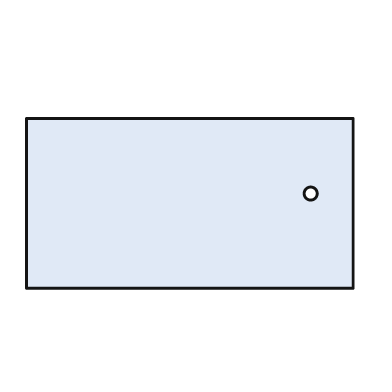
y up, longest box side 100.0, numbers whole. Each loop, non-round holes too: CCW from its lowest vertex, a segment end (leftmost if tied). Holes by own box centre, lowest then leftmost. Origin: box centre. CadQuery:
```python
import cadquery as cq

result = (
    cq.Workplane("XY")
    .moveTo(-50.0, -26.0)
    .lineTo(50.0, -26.0)
    .lineTo(50.0, 26.0)
    .lineTo(-50.0, 26.0)
    .close()
    .moveTo(37.0, 3.0)
    .circle(2.0)
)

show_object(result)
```